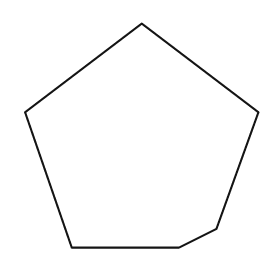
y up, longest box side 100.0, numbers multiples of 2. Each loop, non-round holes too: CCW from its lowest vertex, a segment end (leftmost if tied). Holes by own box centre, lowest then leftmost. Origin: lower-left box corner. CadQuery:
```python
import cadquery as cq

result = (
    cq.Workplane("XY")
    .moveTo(20.0, 0.0)
    .lineTo(66.0, 0.0)
    .lineTo(82.0, 8.0)
    .lineTo(100.0, 58.0)
    .lineTo(50.0, 96.0)
    .lineTo(0.0, 58.0)
    .close()
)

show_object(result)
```